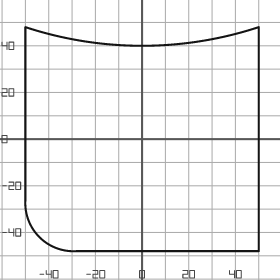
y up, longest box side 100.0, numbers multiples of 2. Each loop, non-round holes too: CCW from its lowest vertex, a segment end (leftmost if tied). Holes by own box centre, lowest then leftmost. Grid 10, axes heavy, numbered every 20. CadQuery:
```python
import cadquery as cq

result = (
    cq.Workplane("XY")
    .moveTo(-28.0, -48.0)
    .lineTo(50.0, -48.0)
    .lineTo(50.0, 48.0)
    .threePointArc((0.0, 40.0), (-50.0, 48.0))
    .lineTo(-50.0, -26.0)
    .threePointArc((-44.0, -42.0), (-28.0, -48.0))
    .close()
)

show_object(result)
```